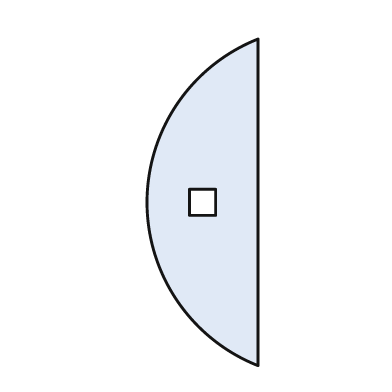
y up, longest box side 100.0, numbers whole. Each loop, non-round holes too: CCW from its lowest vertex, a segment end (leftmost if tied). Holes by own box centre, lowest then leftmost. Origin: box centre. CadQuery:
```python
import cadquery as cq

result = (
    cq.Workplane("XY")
    .moveTo(17.0, -50.0)
    .lineTo(17.0, 50.0)
    .threePointArc((-17.0, 0.0), (17.0, -50.0))
    .close()
    .moveTo(-4.0, -4.0)
    .lineTo(4.0, -4.0)
    .lineTo(4.0, 4.0)
    .lineTo(-4.0, 4.0)
    .close()
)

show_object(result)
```